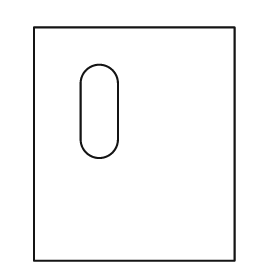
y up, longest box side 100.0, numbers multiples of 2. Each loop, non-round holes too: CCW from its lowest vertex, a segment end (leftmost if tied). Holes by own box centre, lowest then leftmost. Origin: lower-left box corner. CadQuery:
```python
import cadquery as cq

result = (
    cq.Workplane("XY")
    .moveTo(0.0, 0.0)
    .lineTo(86.0, 0.0)
    .lineTo(86.0, 100.0)
    .lineTo(0.0, 100.0)
    .close()
    .moveTo(20.0, 52.0)
    .threePointArc((28.0, 44.0), (36.0, 52.0))
    .lineTo(36.0, 76.0)
    .threePointArc((28.0, 84.0), (20.0, 76.0))
    .close()
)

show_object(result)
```